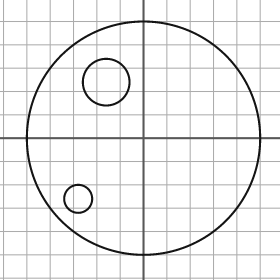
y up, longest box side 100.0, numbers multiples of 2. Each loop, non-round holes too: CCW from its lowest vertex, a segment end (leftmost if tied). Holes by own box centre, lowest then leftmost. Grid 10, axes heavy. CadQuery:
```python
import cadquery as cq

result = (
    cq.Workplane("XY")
    .moveTo(0.0, 0.0)
    .circle(50.0)
    .moveTo(-28.0, -26.0)
    .circle(6.0)
    .moveTo(-16.0, 24.0)
    .circle(10.0)
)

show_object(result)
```